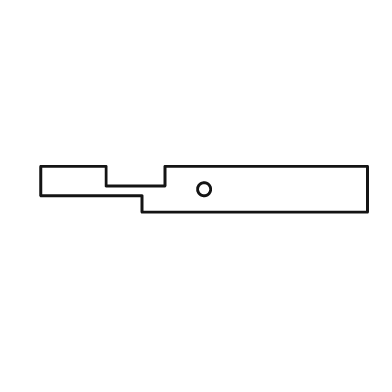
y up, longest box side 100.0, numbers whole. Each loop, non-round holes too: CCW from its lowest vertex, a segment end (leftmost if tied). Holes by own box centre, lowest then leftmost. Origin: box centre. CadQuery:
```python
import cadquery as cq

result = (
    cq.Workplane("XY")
    .moveTo(-19.0, -7.0)
    .lineTo(50.0, -7.0)
    .lineTo(50.0, 7.0)
    .lineTo(-12.0, 7.0)
    .lineTo(-12.0, 1.0)
    .lineTo(-30.0, 1.0)
    .lineTo(-30.0, 7.0)
    .lineTo(-50.0, 7.0)
    .lineTo(-50.0, -2.0)
    .lineTo(-19.0, -2.0)
    .close()
    .moveTo(0.0, 0.0)
    .circle(2.0)
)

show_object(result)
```